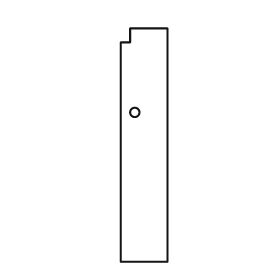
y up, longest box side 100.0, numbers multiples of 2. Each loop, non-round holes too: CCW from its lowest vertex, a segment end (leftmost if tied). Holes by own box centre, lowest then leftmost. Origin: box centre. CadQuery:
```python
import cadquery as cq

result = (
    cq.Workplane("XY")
    .moveTo(-10.0, -50.0)
    .lineTo(10.0, -50.0)
    .lineTo(10.0, 50.0)
    .lineTo(-6.0, 50.0)
    .lineTo(-6.0, 44.0)
    .lineTo(-10.0, 44.0)
    .close()
    .moveTo(-4.0, 14.0)
    .circle(2.0)
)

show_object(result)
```